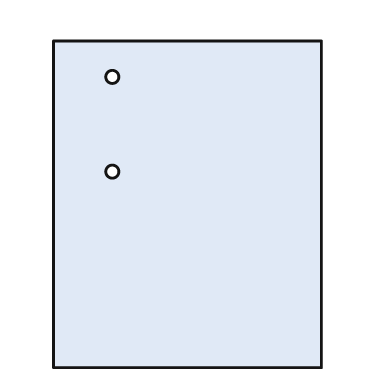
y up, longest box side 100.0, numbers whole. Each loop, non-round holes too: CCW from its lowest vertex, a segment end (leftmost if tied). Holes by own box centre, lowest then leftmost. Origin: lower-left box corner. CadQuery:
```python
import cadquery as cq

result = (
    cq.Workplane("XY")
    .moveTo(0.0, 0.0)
    .lineTo(82.0, 0.0)
    .lineTo(82.0, 100.0)
    .lineTo(0.0, 100.0)
    .close()
    .moveTo(18.0, 60.0)
    .circle(2.0)
    .moveTo(18.0, 89.0)
    .circle(2.0)
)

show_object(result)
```